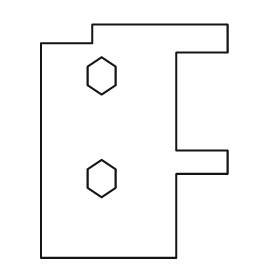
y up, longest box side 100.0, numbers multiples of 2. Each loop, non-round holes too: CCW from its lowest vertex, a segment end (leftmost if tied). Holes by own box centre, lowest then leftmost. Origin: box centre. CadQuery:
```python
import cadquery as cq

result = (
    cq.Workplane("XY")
    .moveTo(-40.0, -50.0)
    .lineTo(18.0, -50.0)
    .lineTo(18.0, -14.0)
    .lineTo(40.0, -14.0)
    .lineTo(40.0, -4.0)
    .lineTo(18.0, -4.0)
    .lineTo(18.0, 38.0)
    .lineTo(40.0, 38.0)
    .lineTo(40.0, 50.0)
    .lineTo(-18.0, 50.0)
    .lineTo(-18.0, 42.0)
    .lineTo(-40.0, 42.0)
    .close()
    .moveTo(-14.0, -24.0)
    .lineTo(-8.0, -20.0)
    .lineTo(-8.0, -12.0)
    .lineTo(-14.0, -8.0)
    .lineTo(-20.0, -12.0)
    .lineTo(-20.0, -20.0)
    .close()
    .moveTo(-14.0, 20.0)
    .lineTo(-8.0, 24.0)
    .lineTo(-8.0, 32.0)
    .lineTo(-14.0, 36.0)
    .lineTo(-20.0, 32.0)
    .lineTo(-20.0, 24.0)
    .close()
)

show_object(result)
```